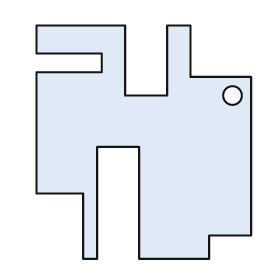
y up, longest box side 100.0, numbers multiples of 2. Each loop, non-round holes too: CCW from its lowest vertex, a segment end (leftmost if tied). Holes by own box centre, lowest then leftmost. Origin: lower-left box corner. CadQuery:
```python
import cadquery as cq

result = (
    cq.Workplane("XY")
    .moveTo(20.0, 0.0)
    .lineTo(26.0, 0.0)
    .lineTo(26.0, 48.0)
    .lineTo(44.0, 48.0)
    .lineTo(44.0, 0.0)
    .lineTo(74.0, 0.0)
    .lineTo(74.0, 10.0)
    .lineTo(92.0, 10.0)
    .lineTo(92.0, 78.0)
    .lineTo(66.0, 78.0)
    .lineTo(66.0, 100.0)
    .lineTo(56.0, 100.0)
    .lineTo(56.0, 70.0)
    .lineTo(38.0, 70.0)
    .lineTo(38.0, 100.0)
    .lineTo(0.0, 100.0)
    .lineTo(0.0, 88.0)
    .lineTo(28.0, 88.0)
    .lineTo(28.0, 80.0)
    .lineTo(0.0, 80.0)
    .lineTo(0.0, 28.0)
    .lineTo(20.0, 28.0)
    .close()
    .moveTo(84.0, 70.0)
    .circle(4.0)
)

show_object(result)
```